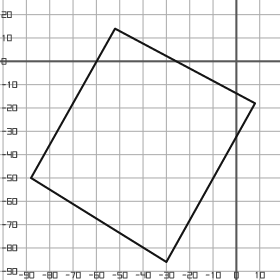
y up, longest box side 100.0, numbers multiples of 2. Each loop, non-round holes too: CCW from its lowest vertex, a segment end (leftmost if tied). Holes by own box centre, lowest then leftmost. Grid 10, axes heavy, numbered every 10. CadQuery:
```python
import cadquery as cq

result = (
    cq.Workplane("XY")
    .moveTo(-30.0, -86.0)
    .lineTo(8.0, -18.0)
    .lineTo(-52.0, 14.0)
    .lineTo(-88.0, -50.0)
    .close()
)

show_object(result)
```